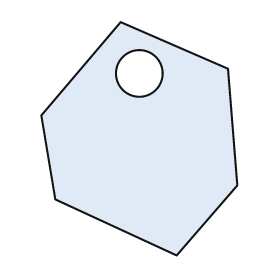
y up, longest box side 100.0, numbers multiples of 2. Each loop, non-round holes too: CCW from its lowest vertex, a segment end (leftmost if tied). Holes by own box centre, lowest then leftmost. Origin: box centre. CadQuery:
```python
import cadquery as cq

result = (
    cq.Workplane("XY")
    .moveTo(16.0, -50.0)
    .lineTo(42.0, -20.0)
    .lineTo(38.0, 30.0)
    .lineTo(-8.0, 50.0)
    .lineTo(-42.0, 10.0)
    .lineTo(-36.0, -26.0)
    .close()
    .moveTo(0.0, 28.0)
    .circle(10.0)
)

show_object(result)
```